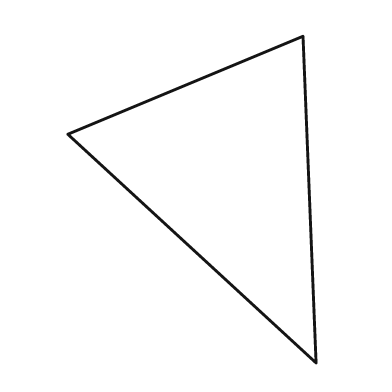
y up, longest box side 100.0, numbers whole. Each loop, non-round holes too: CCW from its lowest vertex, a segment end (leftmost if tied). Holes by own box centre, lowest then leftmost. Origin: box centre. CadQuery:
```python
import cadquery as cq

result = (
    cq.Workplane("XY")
    .moveTo(38.0, -50.0)
    .lineTo(34.0, 50.0)
    .lineTo(-38.0, 20.0)
    .close()
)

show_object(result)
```